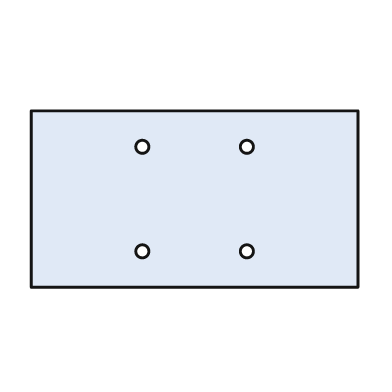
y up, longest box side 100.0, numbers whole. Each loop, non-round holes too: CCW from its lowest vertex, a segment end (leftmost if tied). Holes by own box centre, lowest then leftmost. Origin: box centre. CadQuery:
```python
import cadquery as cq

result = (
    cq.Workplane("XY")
    .moveTo(-50.0, -27.0)
    .lineTo(50.0, -27.0)
    .lineTo(50.0, 27.0)
    .lineTo(-50.0, 27.0)
    .close()
    .moveTo(-16.0, -16.0)
    .circle(2.0)
    .moveTo(16.0, -16.0)
    .circle(2.0)
    .moveTo(-16.0, 16.0)
    .circle(2.0)
    .moveTo(16.0, 16.0)
    .circle(2.0)
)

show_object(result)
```